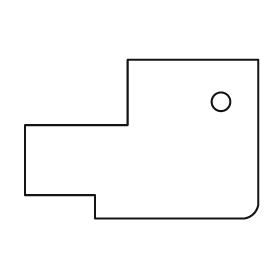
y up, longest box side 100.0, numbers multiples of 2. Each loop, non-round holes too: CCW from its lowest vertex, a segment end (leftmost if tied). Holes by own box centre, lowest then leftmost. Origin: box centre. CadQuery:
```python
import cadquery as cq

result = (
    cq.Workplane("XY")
    .moveTo(-20.0, -34.0)
    .lineTo(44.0, -34.0)
    .threePointArc((48.0, -32.0), (50.0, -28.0))
    .lineTo(50.0, 34.0)
    .lineTo(-6.0, 34.0)
    .lineTo(-6.0, 6.0)
    .lineTo(-50.0, 6.0)
    .lineTo(-50.0, -24.0)
    .lineTo(-20.0, -24.0)
    .close()
    .moveTo(34.0, 16.0)
    .circle(4.0)
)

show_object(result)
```